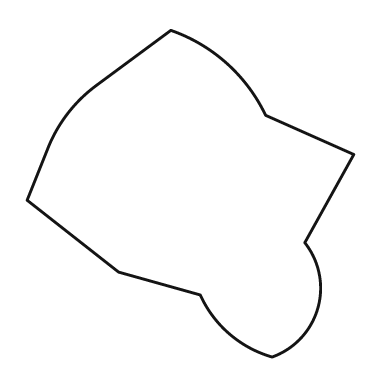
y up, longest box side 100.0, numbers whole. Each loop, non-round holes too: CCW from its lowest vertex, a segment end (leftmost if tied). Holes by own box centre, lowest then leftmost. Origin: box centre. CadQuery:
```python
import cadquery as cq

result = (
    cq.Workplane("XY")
    .moveTo(25.0, -50.0)
    .threePointArc((39.0, -35.0), (35.0, -15.0))
    .lineTo(50.0, 12.0)
    .lineTo(23.0, 24.0)
    .threePointArc((11.0, 40.0), (-6.0, 50.0))
    .lineTo(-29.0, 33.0)
    .threePointArc((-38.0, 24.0), (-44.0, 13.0))
    .lineTo(-50.0, -2.0)
    .lineTo(-22.0, -24.0)
    .lineTo(3.0, -31.0)
    .threePointArc((12.0, -43.0), (25.0, -50.0))
    .close()
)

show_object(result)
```